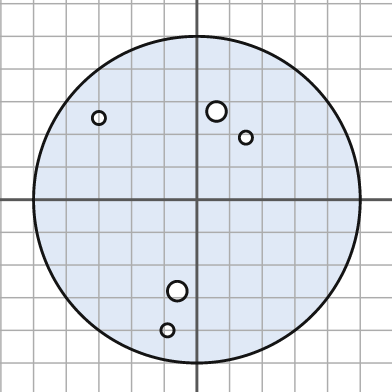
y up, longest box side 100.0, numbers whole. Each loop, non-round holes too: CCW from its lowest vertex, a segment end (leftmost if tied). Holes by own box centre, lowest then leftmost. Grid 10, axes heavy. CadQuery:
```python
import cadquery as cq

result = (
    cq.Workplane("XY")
    .moveTo(0.0, 0.0)
    .circle(50.0)
    .moveTo(-9.0, -40.0)
    .circle(2.0)
    .moveTo(-6.0, -28.0)
    .circle(3.0)
    .moveTo(15.0, 19.0)
    .circle(2.0)
    .moveTo(-30.0, 25.0)
    .circle(2.0)
    .moveTo(6.0, 27.0)
    .circle(3.0)
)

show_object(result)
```